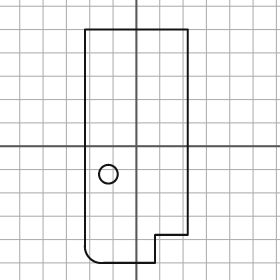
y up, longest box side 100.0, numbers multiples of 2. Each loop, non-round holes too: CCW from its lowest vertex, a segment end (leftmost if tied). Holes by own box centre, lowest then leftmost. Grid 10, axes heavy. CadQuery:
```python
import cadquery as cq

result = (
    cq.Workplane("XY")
    .moveTo(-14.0, -50.0)
    .lineTo(8.0, -50.0)
    .lineTo(8.0, -38.0)
    .lineTo(22.0, -38.0)
    .lineTo(22.0, 50.0)
    .lineTo(-22.0, 50.0)
    .lineTo(-22.0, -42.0)
    .threePointArc((-20.0, -48.0), (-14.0, -50.0))
    .close()
    .moveTo(-12.0, -12.0)
    .circle(4.0)
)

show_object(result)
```